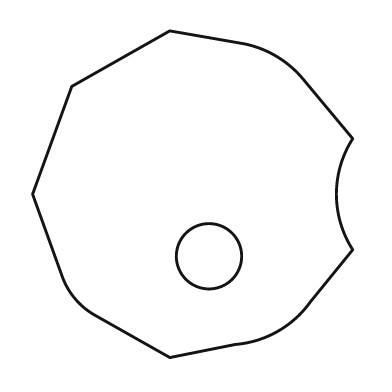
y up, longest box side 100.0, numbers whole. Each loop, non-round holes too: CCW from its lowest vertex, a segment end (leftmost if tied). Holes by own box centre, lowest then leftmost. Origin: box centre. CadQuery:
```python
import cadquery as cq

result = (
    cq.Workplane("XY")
    .moveTo(-7.0, -50.0)
    .lineTo(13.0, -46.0)
    .threePointArc((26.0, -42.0), (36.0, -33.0))
    .lineTo(49.0, -17.0)
    .threePointArc((44.0, 0.0), (49.0, 17.0))
    .lineTo(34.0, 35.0)
    .threePointArc((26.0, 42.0), (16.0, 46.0))
    .lineTo(-7.0, 50.0)
    .lineTo(-37.0, 33.0)
    .lineTo(-49.0, 0.0)
    .lineTo(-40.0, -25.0)
    .threePointArc((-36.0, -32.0), (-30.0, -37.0))
    .close()
    .moveTo(5.0, -19.0)
    .circle(10.0)
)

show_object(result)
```